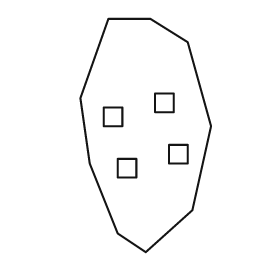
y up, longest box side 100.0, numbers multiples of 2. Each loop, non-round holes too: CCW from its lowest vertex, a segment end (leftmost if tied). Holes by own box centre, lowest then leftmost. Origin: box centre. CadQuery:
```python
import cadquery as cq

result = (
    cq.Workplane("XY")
    .moveTo(0.0, -50.0)
    .lineTo(20.0, -32.0)
    .lineTo(28.0, 4.0)
    .lineTo(18.0, 40.0)
    .lineTo(2.0, 50.0)
    .lineTo(-16.0, 50.0)
    .lineTo(-28.0, 16.0)
    .lineTo(-24.0, -12.0)
    .lineTo(-12.0, -42.0)
    .close()
    .moveTo(-12.0, -18.0)
    .lineTo(-4.0, -18.0)
    .lineTo(-4.0, -10.0)
    .lineTo(-12.0, -10.0)
    .close()
    .moveTo(10.0, -12.0)
    .lineTo(18.0, -12.0)
    .lineTo(18.0, -4.0)
    .lineTo(10.0, -4.0)
    .close()
    .moveTo(-18.0, 4.0)
    .lineTo(-10.0, 4.0)
    .lineTo(-10.0, 12.0)
    .lineTo(-18.0, 12.0)
    .close()
    .moveTo(4.0, 10.0)
    .lineTo(12.0, 10.0)
    .lineTo(12.0, 18.0)
    .lineTo(4.0, 18.0)
    .close()
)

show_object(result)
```